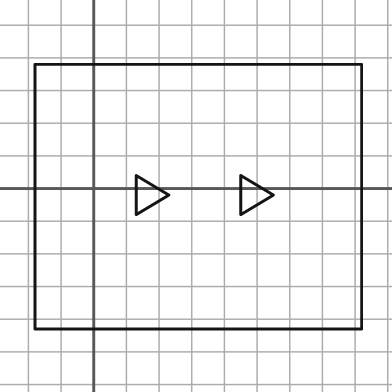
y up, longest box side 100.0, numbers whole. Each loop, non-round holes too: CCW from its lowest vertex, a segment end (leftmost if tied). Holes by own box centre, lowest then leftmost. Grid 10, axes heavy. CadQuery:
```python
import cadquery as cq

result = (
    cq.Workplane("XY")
    .moveTo(-18.0, -43.0)
    .lineTo(82.0, -43.0)
    .lineTo(82.0, 38.0)
    .lineTo(-18.0, 38.0)
    .close()
    .moveTo(13.0, -8.0)
    .lineTo(23.0, -2.0)
    .lineTo(13.0, 4.0)
    .close()
    .moveTo(45.0, -8.0)
    .lineTo(55.0, -2.0)
    .lineTo(45.0, 4.0)
    .close()
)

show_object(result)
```